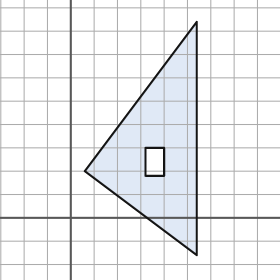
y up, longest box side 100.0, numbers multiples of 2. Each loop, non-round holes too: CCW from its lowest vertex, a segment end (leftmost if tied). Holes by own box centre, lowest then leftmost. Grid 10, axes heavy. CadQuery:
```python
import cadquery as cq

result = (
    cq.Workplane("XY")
    .moveTo(54.0, -16.0)
    .lineTo(54.0, 84.0)
    .lineTo(6.0, 20.0)
    .close()
    .moveTo(32.0, 18.0)
    .lineTo(40.0, 18.0)
    .lineTo(40.0, 30.0)
    .lineTo(32.0, 30.0)
    .close()
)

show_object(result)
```